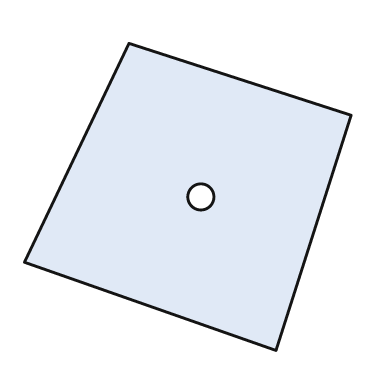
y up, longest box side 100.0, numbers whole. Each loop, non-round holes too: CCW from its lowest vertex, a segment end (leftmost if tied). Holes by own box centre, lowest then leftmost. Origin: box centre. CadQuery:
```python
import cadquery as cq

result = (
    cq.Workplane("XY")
    .moveTo(27.0, -47.0)
    .lineTo(50.0, 25.0)
    .lineTo(-18.0, 47.0)
    .lineTo(-50.0, -20.0)
    .close()
    .moveTo(4.0, 0.0)
    .circle(4.0)
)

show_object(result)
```